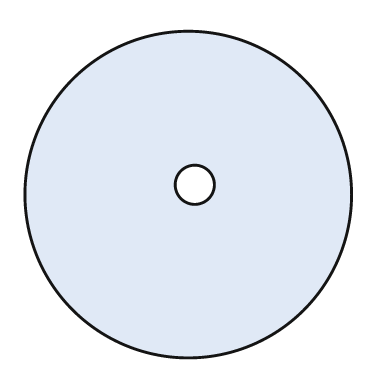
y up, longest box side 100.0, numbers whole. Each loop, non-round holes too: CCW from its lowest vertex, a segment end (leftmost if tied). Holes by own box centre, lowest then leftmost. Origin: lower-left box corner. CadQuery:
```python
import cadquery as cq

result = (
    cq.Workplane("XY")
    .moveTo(50.0, 50.0)
    .circle(50.0)
    .moveTo(52.0, 53.0)
    .circle(6.0)
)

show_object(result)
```